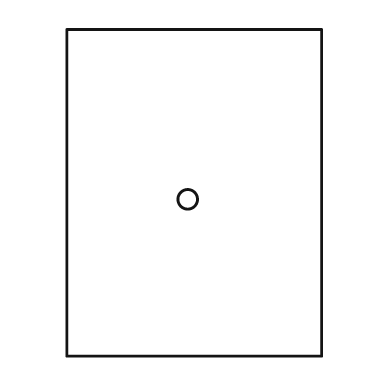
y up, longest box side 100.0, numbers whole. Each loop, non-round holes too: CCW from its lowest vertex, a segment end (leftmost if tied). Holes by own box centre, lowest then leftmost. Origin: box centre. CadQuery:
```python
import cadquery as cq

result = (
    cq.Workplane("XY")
    .moveTo(-39.0, -50.0)
    .lineTo(39.0, -50.0)
    .lineTo(39.0, 50.0)
    .lineTo(-39.0, 50.0)
    .close()
    .moveTo(-2.0, -2.0)
    .circle(3.0)
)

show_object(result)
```